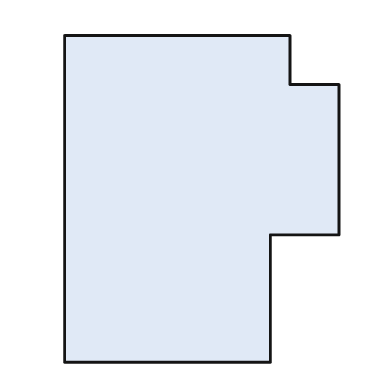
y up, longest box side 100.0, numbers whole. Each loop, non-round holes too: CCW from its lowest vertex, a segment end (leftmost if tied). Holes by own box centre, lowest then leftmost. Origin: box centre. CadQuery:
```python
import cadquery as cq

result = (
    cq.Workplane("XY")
    .moveTo(-42.0, -50.0)
    .lineTo(21.0, -50.0)
    .lineTo(21.0, -11.0)
    .lineTo(42.0, -11.0)
    .lineTo(42.0, 35.0)
    .lineTo(27.0, 35.0)
    .lineTo(27.0, 50.0)
    .lineTo(-42.0, 50.0)
    .close()
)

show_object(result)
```